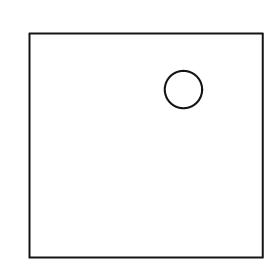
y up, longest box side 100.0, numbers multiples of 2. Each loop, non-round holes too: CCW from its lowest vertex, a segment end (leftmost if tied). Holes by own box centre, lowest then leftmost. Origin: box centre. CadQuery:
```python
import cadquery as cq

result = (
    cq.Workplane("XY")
    .moveTo(-50.0, -48.0)
    .lineTo(50.0, -48.0)
    .lineTo(50.0, 48.0)
    .lineTo(-50.0, 48.0)
    .close()
    .moveTo(16.0, 24.0)
    .circle(8.0)
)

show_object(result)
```